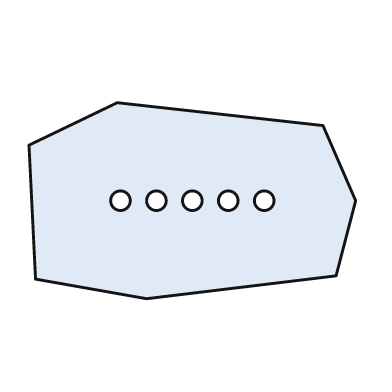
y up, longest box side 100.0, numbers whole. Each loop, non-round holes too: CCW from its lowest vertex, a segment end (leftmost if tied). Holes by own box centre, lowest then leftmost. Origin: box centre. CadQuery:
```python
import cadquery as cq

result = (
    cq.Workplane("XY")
    .moveTo(-14.0, -30.0)
    .lineTo(44.0, -23.0)
    .lineTo(50.0, 0.0)
    .lineTo(40.0, 23.0)
    .lineTo(-23.0, 30.0)
    .lineTo(-50.0, 17.0)
    .lineTo(-48.0, -24.0)
    .close()
    .moveTo(-22.0, 0.0)
    .circle(3.0)
    .moveTo(-11.0, 0.0)
    .circle(3.0)
    .moveTo(0.0, 0.0)
    .circle(3.0)
    .moveTo(11.0, 0.0)
    .circle(3.0)
    .moveTo(22.0, 0.0)
    .circle(3.0)
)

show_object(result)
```